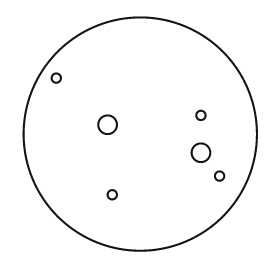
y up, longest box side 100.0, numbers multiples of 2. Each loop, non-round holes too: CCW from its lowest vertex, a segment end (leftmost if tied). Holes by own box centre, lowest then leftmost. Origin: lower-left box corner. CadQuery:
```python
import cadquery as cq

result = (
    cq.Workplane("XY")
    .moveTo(50.0, 50.0)
    .circle(50.0)
    .moveTo(38.0, 24.0)
    .circle(2.0)
    .moveTo(84.0, 32.0)
    .circle(2.0)
    .moveTo(76.0, 42.0)
    .circle(4.0)
    .moveTo(36.0, 54.0)
    .circle(4.0)
    .moveTo(76.0, 58.0)
    .circle(2.0)
    .moveTo(14.0, 74.0)
    .circle(2.0)
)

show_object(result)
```